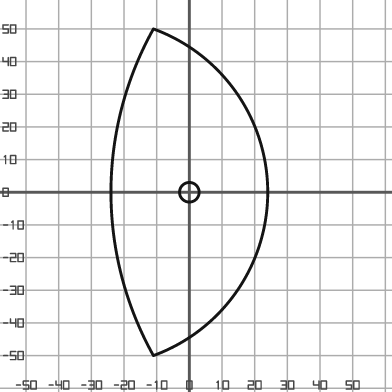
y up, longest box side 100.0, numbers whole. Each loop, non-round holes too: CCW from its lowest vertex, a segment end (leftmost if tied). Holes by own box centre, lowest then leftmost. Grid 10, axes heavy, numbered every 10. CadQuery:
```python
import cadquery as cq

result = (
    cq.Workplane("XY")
    .moveTo(-11.0, -50.0)
    .threePointArc((24.0, 0.0), (-11.0, 50.0))
    .threePointArc((-24.0, 0.0), (-11.0, -50.0))
    .close()
    .moveTo(0.0, 0.0)
    .circle(3.0)
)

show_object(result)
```